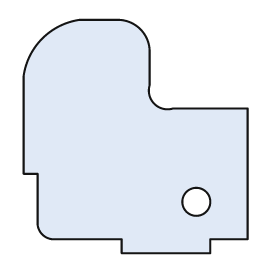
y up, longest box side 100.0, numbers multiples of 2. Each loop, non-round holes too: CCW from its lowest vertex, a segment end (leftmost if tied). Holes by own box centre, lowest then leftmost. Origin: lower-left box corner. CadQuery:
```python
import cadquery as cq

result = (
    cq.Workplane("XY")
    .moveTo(42.0, 0.0)
    .lineTo(80.0, 0.0)
    .lineTo(80.0, 6.0)
    .lineTo(96.0, 6.0)
    .lineTo(96.0, 62.0)
    .lineTo(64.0, 62.0)
    .threePointArc((56.0, 64.0), (54.0, 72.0))
    .lineTo(54.0, 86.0)
    .threePointArc((50.0, 96.0), (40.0, 100.0))
    .lineTo(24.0, 100.0)
    .threePointArc((8.0, 92.0), (0.0, 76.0))
    .lineTo(0.0, 34.0)
    .lineTo(6.0, 34.0)
    .lineTo(6.0, 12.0)
    .threePointArc((8.0, 8.0), (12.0, 6.0))
    .lineTo(42.0, 6.0)
    .close()
    .moveTo(74.0, 22.0)
    .circle(6.0)
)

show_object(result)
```